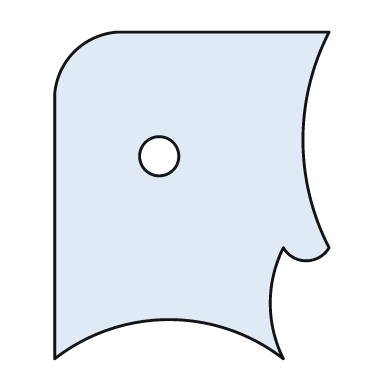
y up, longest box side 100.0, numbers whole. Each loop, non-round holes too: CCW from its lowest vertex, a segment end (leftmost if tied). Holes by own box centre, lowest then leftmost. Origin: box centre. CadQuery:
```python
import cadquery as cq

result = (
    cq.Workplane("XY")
    .moveTo(-42.0, -50.0)
    .threePointArc((-7.0, -38.0), (28.0, -50.0))
    .threePointArc((24.0, -33.0), (28.0, -16.0))
    .threePointArc((35.0, -20.0), (42.0, -16.0))
    .threePointArc((34.0, 17.0), (42.0, 50.0))
    .lineTo(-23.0, 50.0)
    .threePointArc((-36.0, 44.0), (-42.0, 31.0))
    .close()
    .moveTo(-10.0, 12.0)
    .circle(6.0)
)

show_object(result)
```